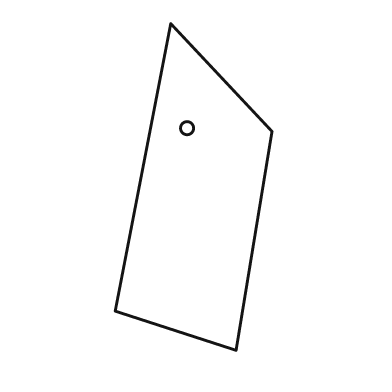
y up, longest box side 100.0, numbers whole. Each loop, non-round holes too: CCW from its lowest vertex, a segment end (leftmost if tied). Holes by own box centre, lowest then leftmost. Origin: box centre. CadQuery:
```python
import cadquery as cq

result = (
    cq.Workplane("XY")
    .moveTo(13.0, -50.0)
    .lineTo(24.0, 17.0)
    .lineTo(-7.0, 50.0)
    .lineTo(-24.0, -38.0)
    .close()
    .moveTo(-2.0, 18.0)
    .circle(2.0)
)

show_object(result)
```